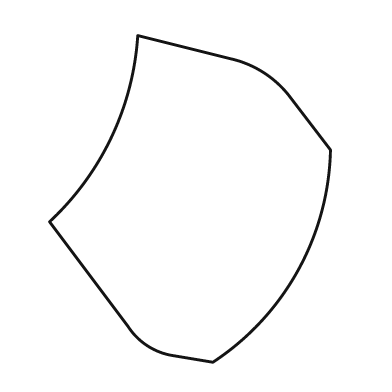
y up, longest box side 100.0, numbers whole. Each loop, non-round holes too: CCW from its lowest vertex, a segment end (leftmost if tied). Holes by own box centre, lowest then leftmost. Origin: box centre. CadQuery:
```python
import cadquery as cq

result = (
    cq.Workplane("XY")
    .moveTo(7.0, -50.0)
    .threePointArc((33.0, -22.0), (43.0, 15.0))
    .lineTo(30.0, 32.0)
    .threePointArc((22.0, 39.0), (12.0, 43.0))
    .lineTo(-16.0, 50.0)
    .threePointArc((-24.0, 19.0), (-43.0, -7.0))
    .lineTo(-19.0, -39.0)
    .threePointArc((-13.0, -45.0), (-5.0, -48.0))
    .close()
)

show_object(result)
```